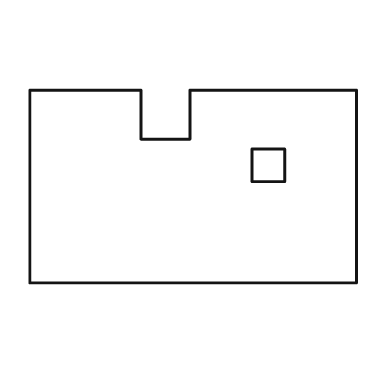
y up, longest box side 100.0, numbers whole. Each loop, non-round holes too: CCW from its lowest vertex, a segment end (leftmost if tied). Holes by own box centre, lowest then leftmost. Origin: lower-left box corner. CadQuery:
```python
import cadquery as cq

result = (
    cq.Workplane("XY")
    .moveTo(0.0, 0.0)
    .lineTo(100.0, 0.0)
    .lineTo(100.0, 59.0)
    .lineTo(49.0, 59.0)
    .lineTo(49.0, 44.0)
    .lineTo(34.0, 44.0)
    .lineTo(34.0, 59.0)
    .lineTo(0.0, 59.0)
    .close()
    .moveTo(68.0, 31.0)
    .lineTo(78.0, 31.0)
    .lineTo(78.0, 41.0)
    .lineTo(68.0, 41.0)
    .close()
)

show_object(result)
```